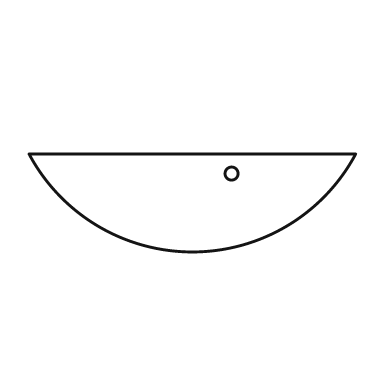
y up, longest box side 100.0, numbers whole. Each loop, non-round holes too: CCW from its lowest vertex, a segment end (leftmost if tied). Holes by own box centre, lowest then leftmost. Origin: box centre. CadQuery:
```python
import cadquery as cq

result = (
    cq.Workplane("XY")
    .moveTo(-50.0, 15.0)
    .threePointArc((0.0, -15.0), (50.0, 15.0))
    .close()
    .moveTo(12.0, 9.0)
    .circle(2.0)
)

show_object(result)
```